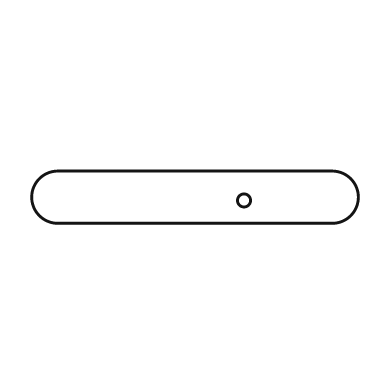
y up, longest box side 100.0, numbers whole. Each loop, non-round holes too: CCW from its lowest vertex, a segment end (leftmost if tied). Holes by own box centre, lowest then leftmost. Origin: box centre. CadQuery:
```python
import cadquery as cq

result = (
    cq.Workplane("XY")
    .moveTo(-42.0, -8.0)
    .lineTo(42.0, -8.0)
    .threePointArc((50.0, 0.0), (42.0, 8.0))
    .lineTo(-42.0, 8.0)
    .threePointArc((-50.0, 0.0), (-42.0, -8.0))
    .close()
    .moveTo(15.0, -1.0)
    .circle(2.0)
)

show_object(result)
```